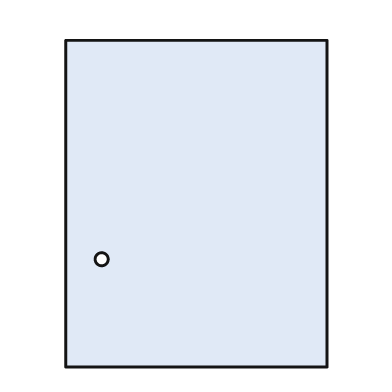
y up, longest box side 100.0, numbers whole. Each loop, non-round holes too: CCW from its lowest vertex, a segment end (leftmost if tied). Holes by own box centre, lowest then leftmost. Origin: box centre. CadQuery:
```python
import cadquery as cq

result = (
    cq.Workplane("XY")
    .moveTo(-40.0, -50.0)
    .lineTo(40.0, -50.0)
    .lineTo(40.0, 50.0)
    .lineTo(-40.0, 50.0)
    .close()
    .moveTo(-29.0, -17.0)
    .circle(2.0)
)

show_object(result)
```